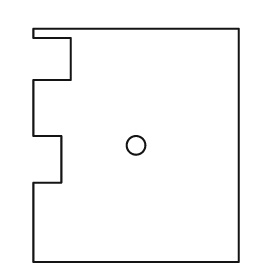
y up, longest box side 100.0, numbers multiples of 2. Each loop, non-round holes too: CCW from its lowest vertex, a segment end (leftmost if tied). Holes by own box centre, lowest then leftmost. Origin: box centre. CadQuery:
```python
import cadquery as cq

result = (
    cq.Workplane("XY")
    .moveTo(-44.0, -50.0)
    .lineTo(44.0, -50.0)
    .lineTo(44.0, 50.0)
    .lineTo(-44.0, 50.0)
    .lineTo(-44.0, 46.0)
    .lineTo(-28.0, 46.0)
    .lineTo(-28.0, 28.0)
    .lineTo(-44.0, 28.0)
    .lineTo(-44.0, 4.0)
    .lineTo(-32.0, 4.0)
    .lineTo(-32.0, -16.0)
    .lineTo(-44.0, -16.0)
    .close()
    .moveTo(0.0, 0.0)
    .circle(4.0)
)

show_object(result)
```